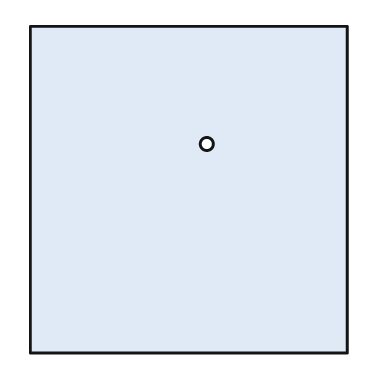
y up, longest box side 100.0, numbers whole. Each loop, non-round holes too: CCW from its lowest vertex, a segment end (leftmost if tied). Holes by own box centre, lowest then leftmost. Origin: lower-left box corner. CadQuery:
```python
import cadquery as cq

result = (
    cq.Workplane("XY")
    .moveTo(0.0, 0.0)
    .lineTo(97.0, 0.0)
    .lineTo(97.0, 100.0)
    .lineTo(0.0, 100.0)
    .close()
    .moveTo(54.0, 64.0)
    .circle(2.0)
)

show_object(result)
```